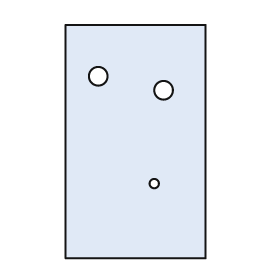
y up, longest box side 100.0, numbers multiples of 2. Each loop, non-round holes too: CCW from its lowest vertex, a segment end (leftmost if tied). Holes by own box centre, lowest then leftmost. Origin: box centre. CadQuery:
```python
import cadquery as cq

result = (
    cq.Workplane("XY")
    .moveTo(-30.0, -50.0)
    .lineTo(30.0, -50.0)
    .lineTo(30.0, 50.0)
    .lineTo(-30.0, 50.0)
    .close()
    .moveTo(8.0, -18.0)
    .circle(2.0)
    .moveTo(12.0, 22.0)
    .circle(4.0)
    .moveTo(-16.0, 28.0)
    .circle(4.0)
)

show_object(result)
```